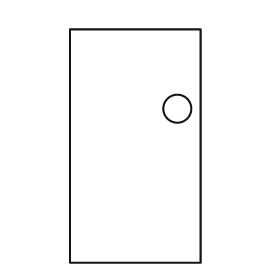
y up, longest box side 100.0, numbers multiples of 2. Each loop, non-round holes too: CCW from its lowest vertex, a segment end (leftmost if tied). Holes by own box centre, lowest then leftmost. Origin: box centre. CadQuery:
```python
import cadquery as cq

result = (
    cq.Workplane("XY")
    .moveTo(-28.0, -50.0)
    .lineTo(28.0, -50.0)
    .lineTo(28.0, 50.0)
    .lineTo(-28.0, 50.0)
    .close()
    .moveTo(18.0, 16.0)
    .circle(6.0)
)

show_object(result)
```